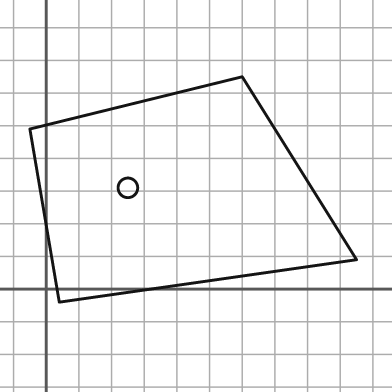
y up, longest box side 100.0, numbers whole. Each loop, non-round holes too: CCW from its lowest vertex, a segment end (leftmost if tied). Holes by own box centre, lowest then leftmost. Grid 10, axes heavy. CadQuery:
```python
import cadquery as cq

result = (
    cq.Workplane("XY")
    .moveTo(4.0, -4.0)
    .lineTo(95.0, 9.0)
    .lineTo(60.0, 65.0)
    .lineTo(-5.0, 49.0)
    .close()
    .moveTo(25.0, 31.0)
    .circle(3.0)
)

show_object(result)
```